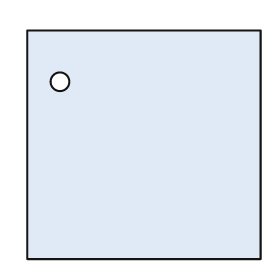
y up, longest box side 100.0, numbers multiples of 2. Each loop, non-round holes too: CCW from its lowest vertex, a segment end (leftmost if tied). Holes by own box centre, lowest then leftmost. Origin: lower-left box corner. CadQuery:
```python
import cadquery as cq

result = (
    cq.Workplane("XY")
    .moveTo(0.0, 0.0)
    .lineTo(100.0, 0.0)
    .lineTo(100.0, 98.0)
    .lineTo(0.0, 98.0)
    .close()
    .moveTo(14.0, 76.0)
    .circle(4.0)
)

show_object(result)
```